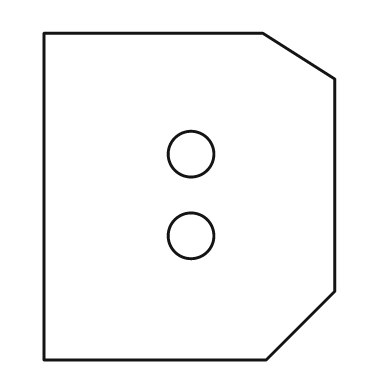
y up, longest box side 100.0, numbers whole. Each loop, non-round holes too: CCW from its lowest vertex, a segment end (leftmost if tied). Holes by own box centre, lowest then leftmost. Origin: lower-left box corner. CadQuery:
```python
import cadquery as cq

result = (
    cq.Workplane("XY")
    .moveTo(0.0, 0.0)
    .lineTo(68.0, 0.0)
    .lineTo(89.0, 21.0)
    .lineTo(89.0, 86.0)
    .lineTo(67.0, 100.0)
    .lineTo(0.0, 100.0)
    .close()
    .moveTo(45.0, 38.0)
    .circle(7.0)
    .moveTo(45.0, 63.0)
    .circle(7.0)
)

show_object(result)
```